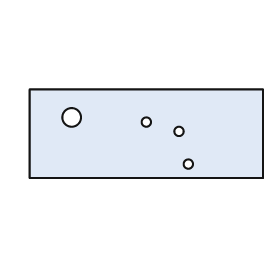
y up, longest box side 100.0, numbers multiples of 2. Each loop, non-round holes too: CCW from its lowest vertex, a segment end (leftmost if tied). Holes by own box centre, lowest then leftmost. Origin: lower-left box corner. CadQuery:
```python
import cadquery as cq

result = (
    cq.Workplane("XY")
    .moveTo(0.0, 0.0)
    .lineTo(100.0, 0.0)
    .lineTo(100.0, 38.0)
    .lineTo(0.0, 38.0)
    .close()
    .moveTo(68.0, 6.0)
    .circle(2.0)
    .moveTo(64.0, 20.0)
    .circle(2.0)
    .moveTo(50.0, 24.0)
    .circle(2.0)
    .moveTo(18.0, 26.0)
    .circle(4.0)
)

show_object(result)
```